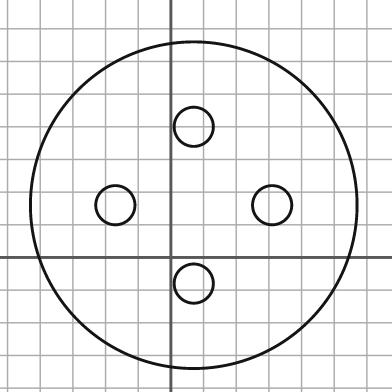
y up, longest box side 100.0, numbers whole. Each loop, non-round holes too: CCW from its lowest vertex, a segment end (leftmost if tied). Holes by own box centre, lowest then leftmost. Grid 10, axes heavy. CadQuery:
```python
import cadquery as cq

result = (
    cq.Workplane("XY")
    .moveTo(7.0, 16.0)
    .circle(50.0)
    .moveTo(7.0, -8.0)
    .circle(6.0)
    .moveTo(-17.0, 16.0)
    .circle(6.0)
    .moveTo(31.0, 16.0)
    .circle(6.0)
    .moveTo(7.0, 40.0)
    .circle(6.0)
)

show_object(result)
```